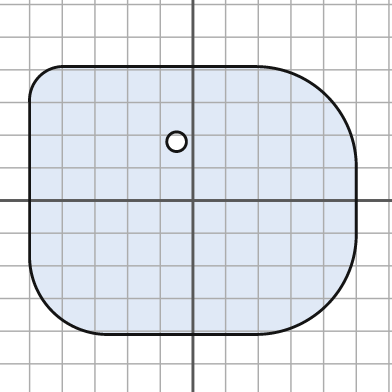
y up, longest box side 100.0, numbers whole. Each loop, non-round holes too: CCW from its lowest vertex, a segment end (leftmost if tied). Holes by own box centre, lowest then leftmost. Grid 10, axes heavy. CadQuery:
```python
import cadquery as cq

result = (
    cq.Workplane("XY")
    .moveTo(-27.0, -41.0)
    .lineTo(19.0, -41.0)
    .threePointArc((41.0, -32.0), (50.0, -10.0))
    .lineTo(50.0, 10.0)
    .threePointArc((41.0, 32.0), (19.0, 41.0))
    .lineTo(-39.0, 41.0)
    .threePointArc((-47.0, 38.0), (-50.0, 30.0))
    .lineTo(-50.0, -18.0)
    .threePointArc((-43.0, -34.0), (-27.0, -41.0))
    .close()
    .moveTo(-5.0, 18.0)
    .circle(3.0)
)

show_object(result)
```